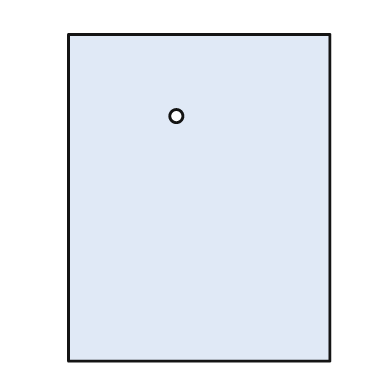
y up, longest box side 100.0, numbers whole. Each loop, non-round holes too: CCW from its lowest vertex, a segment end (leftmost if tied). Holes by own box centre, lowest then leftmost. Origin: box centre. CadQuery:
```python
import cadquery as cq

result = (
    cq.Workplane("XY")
    .moveTo(-40.0, -50.0)
    .lineTo(40.0, -50.0)
    .lineTo(40.0, 50.0)
    .lineTo(-40.0, 50.0)
    .close()
    .moveTo(-7.0, 25.0)
    .circle(2.0)
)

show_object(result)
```